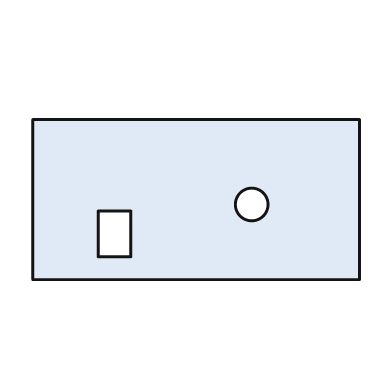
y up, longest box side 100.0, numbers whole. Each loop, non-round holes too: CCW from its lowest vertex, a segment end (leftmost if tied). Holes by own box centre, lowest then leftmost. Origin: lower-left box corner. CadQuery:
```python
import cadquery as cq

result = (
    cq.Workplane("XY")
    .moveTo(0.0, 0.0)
    .lineTo(100.0, 0.0)
    .lineTo(100.0, 49.0)
    .lineTo(0.0, 49.0)
    .close()
    .moveTo(20.0, 7.0)
    .lineTo(30.0, 7.0)
    .lineTo(30.0, 21.0)
    .lineTo(20.0, 21.0)
    .close()
    .moveTo(67.0, 23.0)
    .circle(5.0)
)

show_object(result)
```